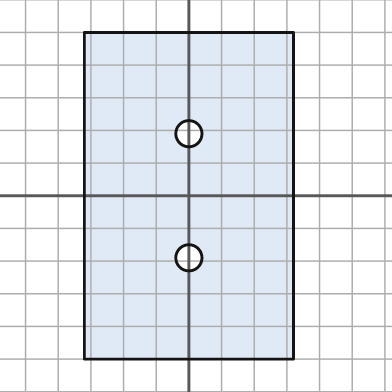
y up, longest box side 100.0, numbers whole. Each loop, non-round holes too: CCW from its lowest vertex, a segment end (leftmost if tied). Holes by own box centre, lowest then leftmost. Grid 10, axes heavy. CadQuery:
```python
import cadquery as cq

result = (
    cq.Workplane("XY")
    .moveTo(-32.0, -50.0)
    .lineTo(32.0, -50.0)
    .lineTo(32.0, 50.0)
    .lineTo(-32.0, 50.0)
    .close()
    .moveTo(0.0, -19.0)
    .circle(4.0)
    .moveTo(0.0, 19.0)
    .circle(4.0)
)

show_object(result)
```